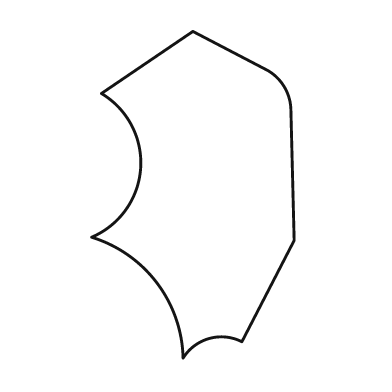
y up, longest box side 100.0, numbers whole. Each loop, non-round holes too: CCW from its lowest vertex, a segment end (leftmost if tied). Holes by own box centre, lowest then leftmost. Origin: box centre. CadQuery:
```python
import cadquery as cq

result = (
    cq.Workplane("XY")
    .moveTo(-3.0, -50.0)
    .threePointArc((5.0, -44.0), (15.0, -45.0))
    .lineTo(31.0, -14.0)
    .lineTo(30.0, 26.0)
    .threePointArc((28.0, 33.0), (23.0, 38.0))
    .lineTo(0.0, 50.0)
    .lineTo(-28.0, 31.0)
    .threePointArc((-16.0, 8.0), (-31.0, -13.0))
    .threePointArc((-11.0, -27.0), (-3.0, -50.0))
    .close()
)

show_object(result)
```